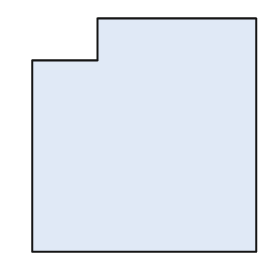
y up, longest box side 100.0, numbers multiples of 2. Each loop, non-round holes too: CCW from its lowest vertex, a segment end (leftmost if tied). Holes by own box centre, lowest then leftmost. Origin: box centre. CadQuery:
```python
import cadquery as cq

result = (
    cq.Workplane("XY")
    .moveTo(-48.0, -50.0)
    .lineTo(48.0, -50.0)
    .lineTo(48.0, 50.0)
    .lineTo(-20.0, 50.0)
    .lineTo(-20.0, 32.0)
    .lineTo(-48.0, 32.0)
    .close()
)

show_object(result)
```